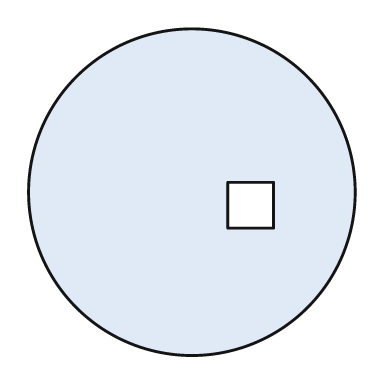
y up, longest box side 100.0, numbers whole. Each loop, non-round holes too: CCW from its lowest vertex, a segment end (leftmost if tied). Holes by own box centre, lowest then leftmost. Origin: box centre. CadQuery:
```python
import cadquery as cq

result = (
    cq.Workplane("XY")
    .moveTo(0.0, 0.0)
    .circle(50.0)
    .moveTo(11.0, -11.0)
    .lineTo(25.0, -11.0)
    .lineTo(25.0, 3.0)
    .lineTo(11.0, 3.0)
    .close()
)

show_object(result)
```